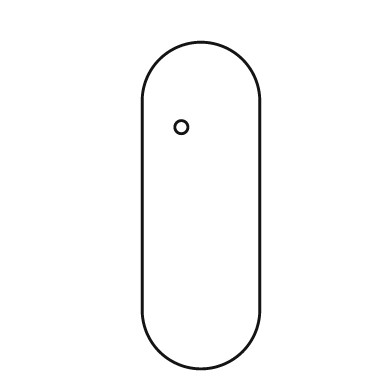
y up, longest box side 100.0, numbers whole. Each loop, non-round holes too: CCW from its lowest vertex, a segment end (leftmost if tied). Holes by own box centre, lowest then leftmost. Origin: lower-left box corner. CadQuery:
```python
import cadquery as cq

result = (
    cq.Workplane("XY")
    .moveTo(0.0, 18.0)
    .threePointArc((18.0, 0.0), (36.0, 18.0))
    .lineTo(36.0, 82.0)
    .threePointArc((18.0, 100.0), (0.0, 82.0))
    .close()
    .moveTo(12.0, 74.0)
    .circle(2.0)
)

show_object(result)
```